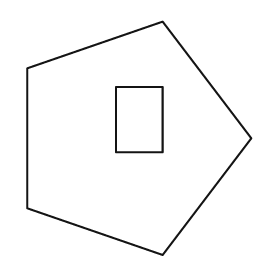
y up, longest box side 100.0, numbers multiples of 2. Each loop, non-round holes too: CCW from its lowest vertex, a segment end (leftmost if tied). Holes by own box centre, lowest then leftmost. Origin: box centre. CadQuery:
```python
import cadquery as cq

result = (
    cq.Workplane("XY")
    .moveTo(10.0, -50.0)
    .lineTo(48.0, 0.0)
    .lineTo(10.0, 50.0)
    .lineTo(-48.0, 30.0)
    .lineTo(-48.0, -30.0)
    .close()
    .moveTo(-10.0, -6.0)
    .lineTo(10.0, -6.0)
    .lineTo(10.0, 22.0)
    .lineTo(-10.0, 22.0)
    .close()
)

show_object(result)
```